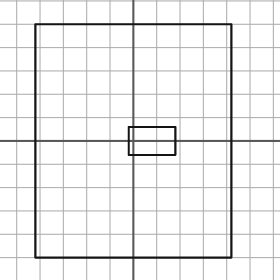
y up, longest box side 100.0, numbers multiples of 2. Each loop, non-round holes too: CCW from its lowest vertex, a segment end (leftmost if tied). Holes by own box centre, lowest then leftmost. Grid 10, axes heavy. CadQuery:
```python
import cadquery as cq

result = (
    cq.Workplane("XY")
    .moveTo(-42.0, -50.0)
    .lineTo(42.0, -50.0)
    .lineTo(42.0, 50.0)
    .lineTo(-42.0, 50.0)
    .close()
    .moveTo(-2.0, -6.0)
    .lineTo(18.0, -6.0)
    .lineTo(18.0, 6.0)
    .lineTo(-2.0, 6.0)
    .close()
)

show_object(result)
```